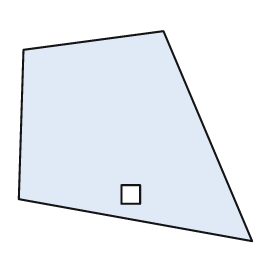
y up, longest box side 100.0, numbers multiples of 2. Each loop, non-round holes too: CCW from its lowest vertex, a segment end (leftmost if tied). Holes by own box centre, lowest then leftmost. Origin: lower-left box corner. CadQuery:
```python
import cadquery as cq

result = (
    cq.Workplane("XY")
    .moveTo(100.0, 0.0)
    .lineTo(62.0, 90.0)
    .lineTo(2.0, 82.0)
    .lineTo(0.0, 18.0)
    .close()
    .moveTo(44.0, 16.0)
    .lineTo(52.0, 16.0)
    .lineTo(52.0, 24.0)
    .lineTo(44.0, 24.0)
    .close()
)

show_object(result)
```